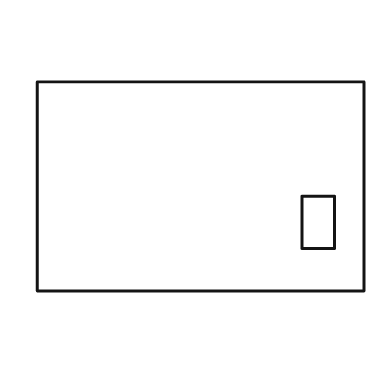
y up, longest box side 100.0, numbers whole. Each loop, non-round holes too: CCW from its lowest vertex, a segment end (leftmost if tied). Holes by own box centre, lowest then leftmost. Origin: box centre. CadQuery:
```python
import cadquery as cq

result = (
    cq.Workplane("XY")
    .moveTo(-50.0, -32.0)
    .lineTo(50.0, -32.0)
    .lineTo(50.0, 32.0)
    .lineTo(-50.0, 32.0)
    .close()
    .moveTo(31.0, -19.0)
    .lineTo(41.0, -19.0)
    .lineTo(41.0, -3.0)
    .lineTo(31.0, -3.0)
    .close()
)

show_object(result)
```